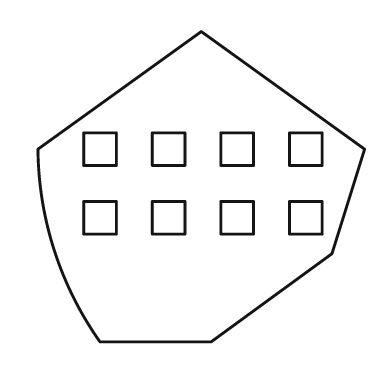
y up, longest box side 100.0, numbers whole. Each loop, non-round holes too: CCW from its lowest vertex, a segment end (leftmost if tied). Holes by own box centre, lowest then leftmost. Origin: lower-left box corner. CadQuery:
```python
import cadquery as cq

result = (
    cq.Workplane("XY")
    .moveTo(19.0, 0.0)
    .lineTo(53.0, 0.0)
    .lineTo(90.0, 27.0)
    .lineTo(100.0, 59.0)
    .lineTo(50.0, 95.0)
    .lineTo(0.0, 59.0)
    .threePointArc((5.0, 28.0), (19.0, 0.0))
    .close()
    .moveTo(14.0, 33.0)
    .lineTo(24.0, 33.0)
    .lineTo(24.0, 43.0)
    .lineTo(14.0, 43.0)
    .close()
    .moveTo(35.0, 33.0)
    .lineTo(45.0, 33.0)
    .lineTo(45.0, 43.0)
    .lineTo(35.0, 43.0)
    .close()
    .moveTo(56.0, 33.0)
    .lineTo(66.0, 33.0)
    .lineTo(66.0, 43.0)
    .lineTo(56.0, 43.0)
    .close()
    .moveTo(77.0, 33.0)
    .lineTo(87.0, 33.0)
    .lineTo(87.0, 43.0)
    .lineTo(77.0, 43.0)
    .close()
    .moveTo(14.0, 54.0)
    .lineTo(24.0, 54.0)
    .lineTo(24.0, 64.0)
    .lineTo(14.0, 64.0)
    .close()
    .moveTo(35.0, 54.0)
    .lineTo(45.0, 54.0)
    .lineTo(45.0, 64.0)
    .lineTo(35.0, 64.0)
    .close()
    .moveTo(56.0, 54.0)
    .lineTo(66.0, 54.0)
    .lineTo(66.0, 64.0)
    .lineTo(56.0, 64.0)
    .close()
    .moveTo(77.0, 54.0)
    .lineTo(87.0, 54.0)
    .lineTo(87.0, 64.0)
    .lineTo(77.0, 64.0)
    .close()
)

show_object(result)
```